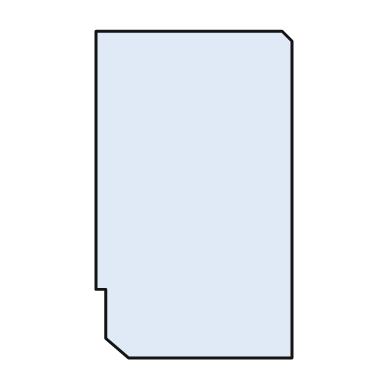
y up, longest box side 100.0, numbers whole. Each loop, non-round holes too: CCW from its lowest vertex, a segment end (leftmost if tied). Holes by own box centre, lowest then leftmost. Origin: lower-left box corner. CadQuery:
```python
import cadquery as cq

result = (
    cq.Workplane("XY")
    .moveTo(10.0, 0.0)
    .lineTo(60.0, 0.0)
    .lineTo(60.0, 97.0)
    .lineTo(57.0, 100.0)
    .lineTo(0.0, 100.0)
    .lineTo(0.0, 21.0)
    .lineTo(3.0, 21.0)
    .lineTo(3.0, 6.0)
    .close()
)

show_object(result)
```